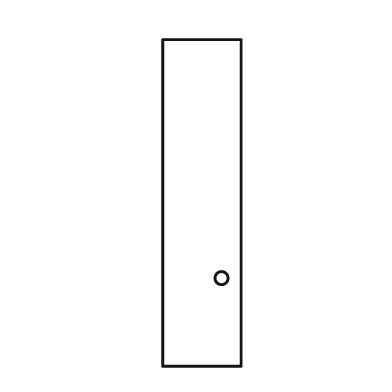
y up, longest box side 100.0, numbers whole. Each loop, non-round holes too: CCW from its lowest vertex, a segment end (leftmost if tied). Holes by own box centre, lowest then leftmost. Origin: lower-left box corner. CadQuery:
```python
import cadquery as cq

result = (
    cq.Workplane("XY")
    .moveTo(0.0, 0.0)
    .lineTo(24.0, 0.0)
    .lineTo(24.0, 100.0)
    .lineTo(0.0, 100.0)
    .close()
    .moveTo(18.0, 27.0)
    .circle(2.0)
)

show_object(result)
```